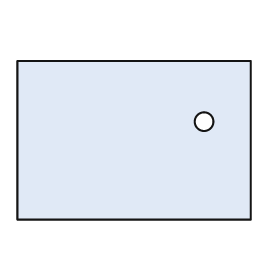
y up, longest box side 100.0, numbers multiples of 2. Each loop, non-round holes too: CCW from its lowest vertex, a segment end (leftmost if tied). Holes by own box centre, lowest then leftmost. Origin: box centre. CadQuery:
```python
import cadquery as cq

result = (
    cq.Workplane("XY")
    .moveTo(-50.0, -34.0)
    .lineTo(50.0, -34.0)
    .lineTo(50.0, 34.0)
    .lineTo(-50.0, 34.0)
    .close()
    .moveTo(30.0, 8.0)
    .circle(4.0)
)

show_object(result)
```